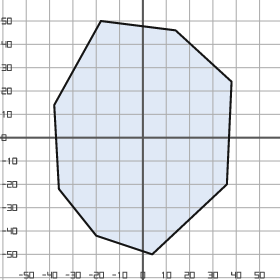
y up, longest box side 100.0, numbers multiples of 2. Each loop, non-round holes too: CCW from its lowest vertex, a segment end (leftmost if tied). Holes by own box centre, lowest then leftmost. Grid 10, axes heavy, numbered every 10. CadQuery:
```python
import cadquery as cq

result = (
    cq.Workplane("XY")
    .moveTo(4.0, -50.0)
    .lineTo(36.0, -20.0)
    .lineTo(38.0, 24.0)
    .lineTo(14.0, 46.0)
    .lineTo(-18.0, 50.0)
    .lineTo(-38.0, 14.0)
    .lineTo(-36.0, -22.0)
    .lineTo(-20.0, -42.0)
    .close()
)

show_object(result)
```